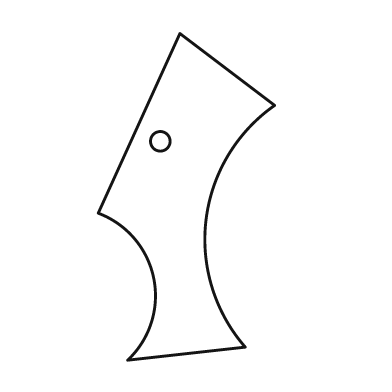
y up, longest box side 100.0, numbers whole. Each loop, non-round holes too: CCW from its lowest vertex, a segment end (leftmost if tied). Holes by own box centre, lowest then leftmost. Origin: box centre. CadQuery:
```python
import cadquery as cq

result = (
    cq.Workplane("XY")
    .moveTo(-18.0, -50.0)
    .lineTo(18.0, -46.0)
    .threePointArc((6.0, -7.0), (27.0, 28.0))
    .lineTo(-2.0, 50.0)
    .lineTo(-27.0, -5.0)
    .threePointArc((-10.0, -25.0), (-18.0, -50.0))
    .close()
    .moveTo(-8.0, 17.0)
    .circle(3.0)
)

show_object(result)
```